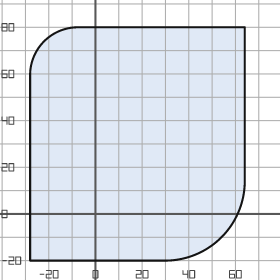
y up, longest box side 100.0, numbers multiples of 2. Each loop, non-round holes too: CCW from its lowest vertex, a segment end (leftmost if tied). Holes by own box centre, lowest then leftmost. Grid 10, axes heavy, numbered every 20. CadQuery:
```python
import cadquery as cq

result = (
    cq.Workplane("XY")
    .moveTo(-28.0, -20.0)
    .lineTo(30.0, -20.0)
    .threePointArc((54.0, -10.0), (64.0, 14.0))
    .lineTo(64.0, 80.0)
    .lineTo(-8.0, 80.0)
    .threePointArc((-22.0, 74.0), (-28.0, 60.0))
    .close()
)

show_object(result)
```